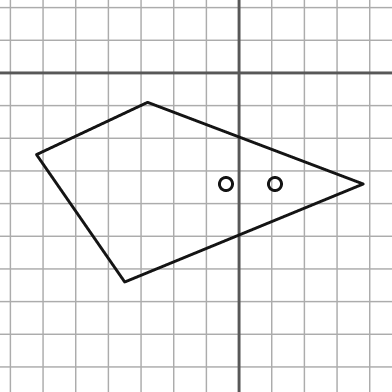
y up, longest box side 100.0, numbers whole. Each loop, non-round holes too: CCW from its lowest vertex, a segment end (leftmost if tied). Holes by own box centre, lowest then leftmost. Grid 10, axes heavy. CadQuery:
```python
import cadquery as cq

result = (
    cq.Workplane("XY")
    .moveTo(-35.0, -64.0)
    .lineTo(38.0, -34.0)
    .lineTo(-28.0, -9.0)
    .lineTo(-62.0, -25.0)
    .close()
    .moveTo(-4.0, -34.0)
    .circle(2.0)
    .moveTo(11.0, -34.0)
    .circle(2.0)
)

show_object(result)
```